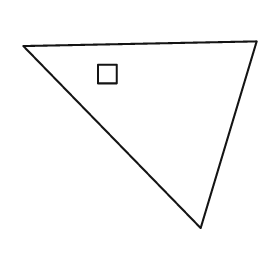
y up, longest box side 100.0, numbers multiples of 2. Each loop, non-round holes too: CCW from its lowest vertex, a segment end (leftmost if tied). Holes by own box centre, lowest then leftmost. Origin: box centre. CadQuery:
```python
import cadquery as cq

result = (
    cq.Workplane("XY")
    .moveTo(26.0, -40.0)
    .lineTo(50.0, 40.0)
    .lineTo(-50.0, 38.0)
    .close()
    .moveTo(-18.0, 22.0)
    .lineTo(-10.0, 22.0)
    .lineTo(-10.0, 30.0)
    .lineTo(-18.0, 30.0)
    .close()
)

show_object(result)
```